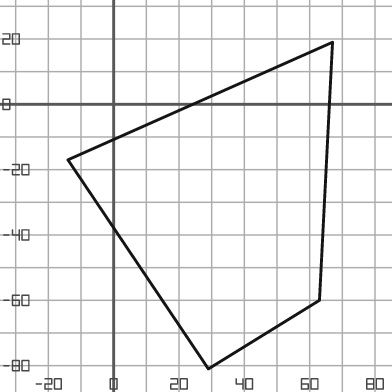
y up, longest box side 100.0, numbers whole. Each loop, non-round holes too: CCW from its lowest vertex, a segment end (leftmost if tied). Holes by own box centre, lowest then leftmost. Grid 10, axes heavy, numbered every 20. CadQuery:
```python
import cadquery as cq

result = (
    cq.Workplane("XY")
    .moveTo(29.0, -81.0)
    .lineTo(63.0, -60.0)
    .lineTo(67.0, 19.0)
    .lineTo(-14.0, -17.0)
    .close()
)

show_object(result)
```